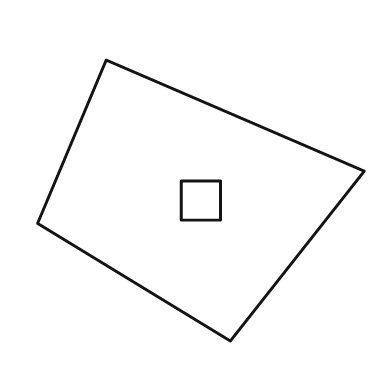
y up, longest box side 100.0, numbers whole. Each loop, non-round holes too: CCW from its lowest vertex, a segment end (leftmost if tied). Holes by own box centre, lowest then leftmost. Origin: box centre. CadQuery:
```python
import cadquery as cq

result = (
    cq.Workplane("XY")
    .moveTo(9.0, -43.0)
    .lineTo(50.0, 9.0)
    .lineTo(-29.0, 43.0)
    .lineTo(-50.0, -7.0)
    .close()
    .moveTo(-6.0, -6.0)
    .lineTo(6.0, -6.0)
    .lineTo(6.0, 6.0)
    .lineTo(-6.0, 6.0)
    .close()
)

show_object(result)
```